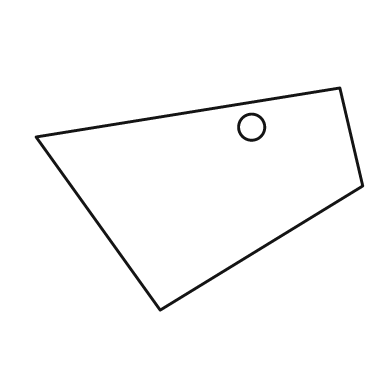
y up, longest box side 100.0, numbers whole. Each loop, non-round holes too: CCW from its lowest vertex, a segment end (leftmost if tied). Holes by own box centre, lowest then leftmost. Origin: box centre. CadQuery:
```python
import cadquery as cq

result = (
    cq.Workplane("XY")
    .moveTo(-12.0, -34.0)
    .lineTo(50.0, 4.0)
    .lineTo(43.0, 34.0)
    .lineTo(-50.0, 19.0)
    .close()
    .moveTo(16.0, 22.0)
    .circle(4.0)
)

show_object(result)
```